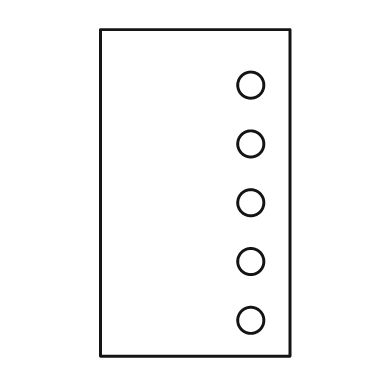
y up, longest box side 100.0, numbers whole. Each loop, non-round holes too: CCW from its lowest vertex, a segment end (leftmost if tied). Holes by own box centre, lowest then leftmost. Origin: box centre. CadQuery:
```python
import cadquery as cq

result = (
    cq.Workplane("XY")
    .moveTo(-29.0, -50.0)
    .lineTo(29.0, -50.0)
    .lineTo(29.0, 50.0)
    .lineTo(-29.0, 50.0)
    .close()
    .moveTo(17.0, -39.0)
    .circle(4.0)
    .moveTo(17.0, -21.0)
    .circle(4.0)
    .moveTo(17.0, -3.0)
    .circle(4.0)
    .moveTo(17.0, 15.0)
    .circle(4.0)
    .moveTo(17.0, 33.0)
    .circle(4.0)
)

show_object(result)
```